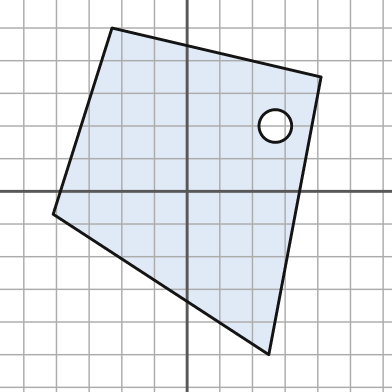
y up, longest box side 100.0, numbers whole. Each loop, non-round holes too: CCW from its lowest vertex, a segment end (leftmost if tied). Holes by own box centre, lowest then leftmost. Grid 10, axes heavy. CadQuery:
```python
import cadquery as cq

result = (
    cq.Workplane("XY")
    .moveTo(25.0, -50.0)
    .lineTo(41.0, 35.0)
    .lineTo(-23.0, 50.0)
    .lineTo(-41.0, -7.0)
    .close()
    .moveTo(27.0, 20.0)
    .circle(5.0)
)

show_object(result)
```